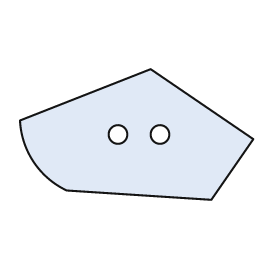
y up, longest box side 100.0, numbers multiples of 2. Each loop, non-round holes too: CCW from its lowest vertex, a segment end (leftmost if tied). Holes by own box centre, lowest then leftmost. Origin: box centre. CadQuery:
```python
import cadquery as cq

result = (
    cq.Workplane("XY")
    .moveTo(32.0, -28.0)
    .lineTo(50.0, -2.0)
    .lineTo(6.0, 28.0)
    .lineTo(-50.0, 6.0)
    .threePointArc((-44.0, -12.0), (-30.0, -24.0))
    .close()
    .moveTo(-8.0, 0.0)
    .circle(4.0)
    .moveTo(10.0, 0.0)
    .circle(4.0)
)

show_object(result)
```